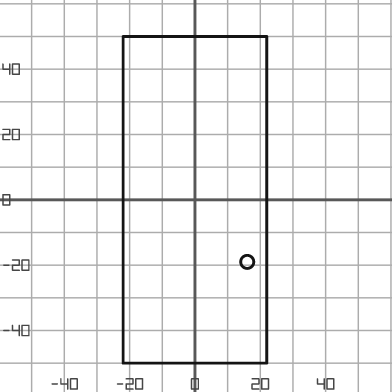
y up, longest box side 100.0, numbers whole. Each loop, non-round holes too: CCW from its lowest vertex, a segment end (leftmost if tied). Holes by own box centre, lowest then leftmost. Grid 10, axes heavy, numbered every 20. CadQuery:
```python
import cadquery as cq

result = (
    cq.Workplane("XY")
    .moveTo(-22.0, -50.0)
    .lineTo(22.0, -50.0)
    .lineTo(22.0, 50.0)
    .lineTo(-22.0, 50.0)
    .close()
    .moveTo(16.0, -19.0)
    .circle(2.0)
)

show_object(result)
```